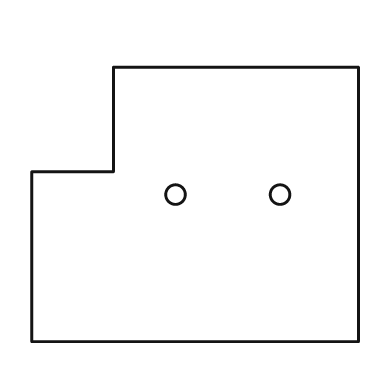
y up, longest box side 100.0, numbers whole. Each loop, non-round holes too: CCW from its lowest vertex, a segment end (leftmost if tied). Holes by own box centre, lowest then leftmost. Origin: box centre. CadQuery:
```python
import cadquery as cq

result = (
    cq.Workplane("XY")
    .moveTo(-50.0, -42.0)
    .lineTo(50.0, -42.0)
    .lineTo(50.0, 42.0)
    .lineTo(-25.0, 42.0)
    .lineTo(-25.0, 10.0)
    .lineTo(-50.0, 10.0)
    .close()
    .moveTo(-6.0, 3.0)
    .circle(3.0)
    .moveTo(26.0, 3.0)
    .circle(3.0)
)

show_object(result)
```